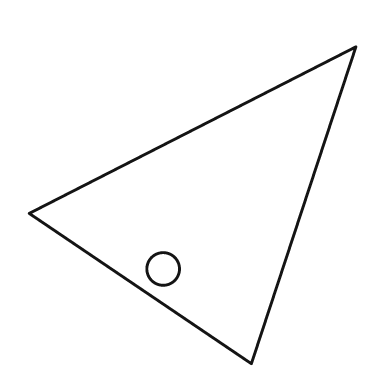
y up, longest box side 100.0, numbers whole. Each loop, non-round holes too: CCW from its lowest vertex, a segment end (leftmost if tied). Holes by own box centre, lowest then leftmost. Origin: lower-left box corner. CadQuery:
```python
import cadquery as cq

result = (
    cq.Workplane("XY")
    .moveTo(68.0, 0.0)
    .lineTo(100.0, 97.0)
    .lineTo(0.0, 46.0)
    .close()
    .moveTo(41.0, 29.0)
    .circle(5.0)
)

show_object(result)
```